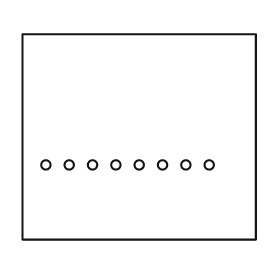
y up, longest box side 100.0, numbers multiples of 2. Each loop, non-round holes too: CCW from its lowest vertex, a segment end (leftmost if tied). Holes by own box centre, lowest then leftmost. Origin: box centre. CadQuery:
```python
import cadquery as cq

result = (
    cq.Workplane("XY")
    .moveTo(-50.0, -44.0)
    .lineTo(50.0, -44.0)
    .lineTo(50.0, 44.0)
    .lineTo(-50.0, 44.0)
    .close()
    .moveTo(-40.0, -12.0)
    .circle(2.0)
    .moveTo(-30.0, -12.0)
    .circle(2.0)
    .moveTo(-20.0, -12.0)
    .circle(2.0)
    .moveTo(-10.0, -12.0)
    .circle(2.0)
    .moveTo(0.0, -12.0)
    .circle(2.0)
    .moveTo(10.0, -12.0)
    .circle(2.0)
    .moveTo(20.0, -12.0)
    .circle(2.0)
    .moveTo(30.0, -12.0)
    .circle(2.0)
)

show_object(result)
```